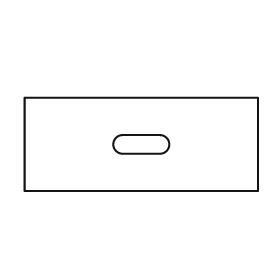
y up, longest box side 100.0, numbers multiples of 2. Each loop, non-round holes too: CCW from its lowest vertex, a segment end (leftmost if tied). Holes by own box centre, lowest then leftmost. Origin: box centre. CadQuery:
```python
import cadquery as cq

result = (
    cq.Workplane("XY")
    .moveTo(-50.0, -20.0)
    .lineTo(50.0, -20.0)
    .lineTo(50.0, 20.0)
    .lineTo(-50.0, 20.0)
    .close()
    .moveTo(-8.0, -4.0)
    .lineTo(8.0, -4.0)
    .threePointArc((12.0, 0.0), (8.0, 4.0))
    .lineTo(-8.0, 4.0)
    .threePointArc((-12.0, 0.0), (-8.0, -4.0))
    .close()
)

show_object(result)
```